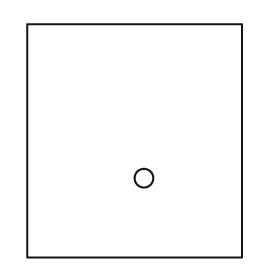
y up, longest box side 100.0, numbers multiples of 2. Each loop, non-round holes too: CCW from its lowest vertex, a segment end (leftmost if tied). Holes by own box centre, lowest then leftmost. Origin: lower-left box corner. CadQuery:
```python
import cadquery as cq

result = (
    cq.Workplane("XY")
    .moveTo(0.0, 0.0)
    .lineTo(92.0, 0.0)
    .lineTo(92.0, 100.0)
    .lineTo(0.0, 100.0)
    .close()
    .moveTo(50.0, 34.0)
    .circle(4.0)
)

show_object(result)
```